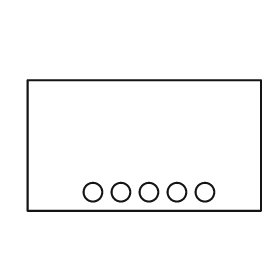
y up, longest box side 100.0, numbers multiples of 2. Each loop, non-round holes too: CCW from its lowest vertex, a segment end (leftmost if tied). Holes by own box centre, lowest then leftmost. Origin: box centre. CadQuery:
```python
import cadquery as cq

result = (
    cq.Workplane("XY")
    .moveTo(-50.0, -28.0)
    .lineTo(50.0, -28.0)
    .lineTo(50.0, 28.0)
    .lineTo(-50.0, 28.0)
    .close()
    .moveTo(-22.0, -20.0)
    .circle(4.0)
    .moveTo(-10.0, -20.0)
    .circle(4.0)
    .moveTo(2.0, -20.0)
    .circle(4.0)
    .moveTo(14.0, -20.0)
    .circle(4.0)
    .moveTo(26.0, -20.0)
    .circle(4.0)
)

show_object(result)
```